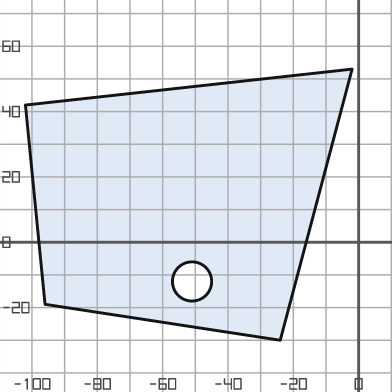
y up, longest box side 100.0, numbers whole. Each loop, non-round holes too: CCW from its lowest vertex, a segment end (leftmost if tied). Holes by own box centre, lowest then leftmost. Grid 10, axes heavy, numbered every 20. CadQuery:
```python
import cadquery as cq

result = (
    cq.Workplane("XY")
    .moveTo(-24.0, -30.0)
    .lineTo(-2.0, 53.0)
    .lineTo(-102.0, 42.0)
    .lineTo(-96.0, -19.0)
    .close()
    .moveTo(-51.0, -12.0)
    .circle(6.0)
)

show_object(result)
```